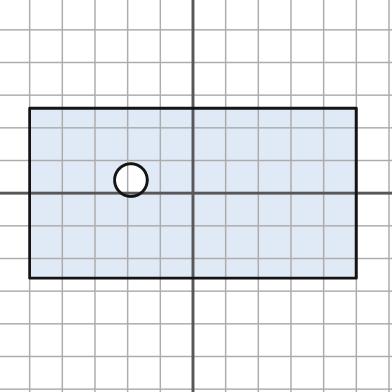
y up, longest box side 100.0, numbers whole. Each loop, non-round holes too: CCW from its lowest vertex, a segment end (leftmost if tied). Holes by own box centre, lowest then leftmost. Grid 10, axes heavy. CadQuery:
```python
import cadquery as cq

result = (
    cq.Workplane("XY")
    .moveTo(-50.0, -26.0)
    .lineTo(50.0, -26.0)
    .lineTo(50.0, 26.0)
    .lineTo(-50.0, 26.0)
    .close()
    .moveTo(-19.0, 4.0)
    .circle(5.0)
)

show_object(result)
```